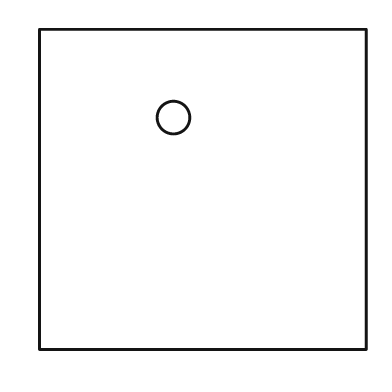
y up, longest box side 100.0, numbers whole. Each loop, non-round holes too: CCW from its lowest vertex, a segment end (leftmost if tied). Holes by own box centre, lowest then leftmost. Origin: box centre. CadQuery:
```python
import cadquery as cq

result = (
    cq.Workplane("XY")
    .moveTo(-50.0, -49.0)
    .lineTo(50.0, -49.0)
    .lineTo(50.0, 49.0)
    .lineTo(-50.0, 49.0)
    .close()
    .moveTo(-9.0, 22.0)
    .circle(5.0)
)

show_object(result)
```